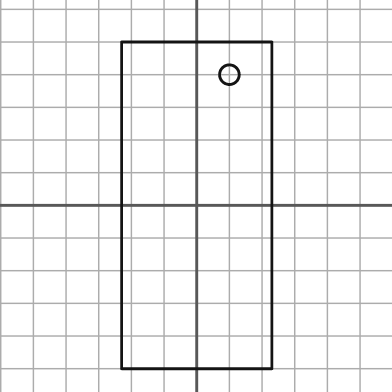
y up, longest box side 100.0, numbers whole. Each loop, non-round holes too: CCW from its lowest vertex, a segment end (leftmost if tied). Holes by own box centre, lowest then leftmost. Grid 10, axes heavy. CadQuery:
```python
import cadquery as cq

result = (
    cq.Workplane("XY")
    .moveTo(-23.0, -50.0)
    .lineTo(23.0, -50.0)
    .lineTo(23.0, 50.0)
    .lineTo(-23.0, 50.0)
    .close()
    .moveTo(10.0, 40.0)
    .circle(3.0)
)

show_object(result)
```